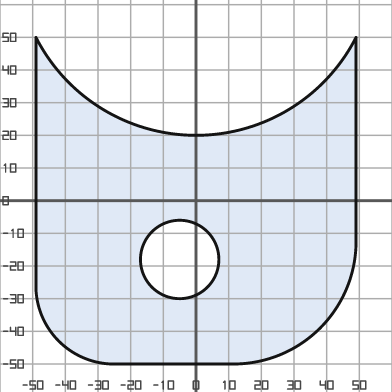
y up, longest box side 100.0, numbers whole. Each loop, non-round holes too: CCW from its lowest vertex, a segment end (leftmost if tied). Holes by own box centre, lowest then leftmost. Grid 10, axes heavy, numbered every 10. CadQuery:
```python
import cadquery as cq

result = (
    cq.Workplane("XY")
    .moveTo(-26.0, -50.0)
    .lineTo(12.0, -50.0)
    .threePointArc((38.0, -39.0), (49.0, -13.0))
    .lineTo(49.0, 50.0)
    .threePointArc((0.0, 20.0), (-49.0, 50.0))
    .lineTo(-49.0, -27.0)
    .threePointArc((-42.0, -43.0), (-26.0, -50.0))
    .close()
    .moveTo(-5.0, -18.0)
    .circle(12.0)
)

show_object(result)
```